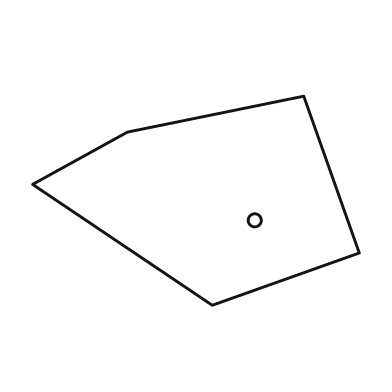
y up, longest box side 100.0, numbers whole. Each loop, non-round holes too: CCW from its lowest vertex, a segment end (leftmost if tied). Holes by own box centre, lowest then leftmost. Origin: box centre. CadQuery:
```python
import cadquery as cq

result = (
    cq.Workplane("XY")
    .moveTo(5.0, -32.0)
    .lineTo(50.0, -16.0)
    .lineTo(33.0, 32.0)
    .lineTo(-21.0, 21.0)
    .lineTo(-50.0, 5.0)
    .close()
    .moveTo(18.0, -6.0)
    .circle(2.0)
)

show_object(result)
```